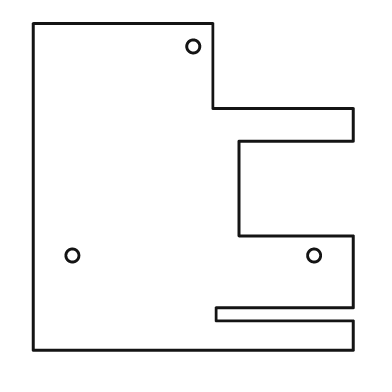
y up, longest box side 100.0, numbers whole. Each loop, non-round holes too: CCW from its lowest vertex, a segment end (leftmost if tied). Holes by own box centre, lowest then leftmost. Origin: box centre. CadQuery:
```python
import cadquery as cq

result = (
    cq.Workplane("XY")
    .moveTo(-49.0, -50.0)
    .lineTo(49.0, -50.0)
    .lineTo(49.0, -41.0)
    .lineTo(7.0, -41.0)
    .lineTo(7.0, -37.0)
    .lineTo(49.0, -37.0)
    .lineTo(49.0, -15.0)
    .lineTo(14.0, -15.0)
    .lineTo(14.0, 14.0)
    .lineTo(49.0, 14.0)
    .lineTo(49.0, 24.0)
    .lineTo(6.0, 24.0)
    .lineTo(6.0, 50.0)
    .lineTo(-49.0, 50.0)
    .close()
    .moveTo(-37.0, -21.0)
    .circle(2.0)
    .moveTo(37.0, -21.0)
    .circle(2.0)
    .moveTo(0.0, 43.0)
    .circle(2.0)
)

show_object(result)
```